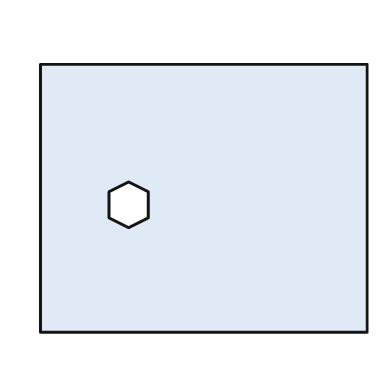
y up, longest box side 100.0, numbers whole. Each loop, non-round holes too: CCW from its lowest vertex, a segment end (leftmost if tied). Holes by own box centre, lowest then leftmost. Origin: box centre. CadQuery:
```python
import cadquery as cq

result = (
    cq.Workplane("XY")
    .moveTo(-50.0, -41.0)
    .lineTo(50.0, -41.0)
    .lineTo(50.0, 41.0)
    .lineTo(-50.0, 41.0)
    .close()
    .moveTo(-23.0, -9.0)
    .lineTo(-17.0, -6.0)
    .lineTo(-17.0, 2.0)
    .lineTo(-23.0, 5.0)
    .lineTo(-29.0, 2.0)
    .lineTo(-29.0, -6.0)
    .close()
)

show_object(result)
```